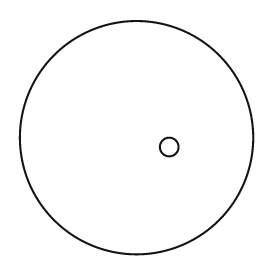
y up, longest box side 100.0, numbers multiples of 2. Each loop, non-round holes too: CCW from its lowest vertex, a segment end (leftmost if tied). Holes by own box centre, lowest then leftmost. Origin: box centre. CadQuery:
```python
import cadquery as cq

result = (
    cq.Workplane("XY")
    .moveTo(0.0, 0.0)
    .circle(50.0)
    .moveTo(14.0, -4.0)
    .circle(4.0)
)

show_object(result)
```